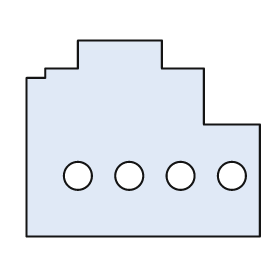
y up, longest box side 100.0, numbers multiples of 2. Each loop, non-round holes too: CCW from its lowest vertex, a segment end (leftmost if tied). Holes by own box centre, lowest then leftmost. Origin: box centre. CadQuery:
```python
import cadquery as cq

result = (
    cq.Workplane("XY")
    .moveTo(-50.0, -42.0)
    .lineTo(50.0, -42.0)
    .lineTo(50.0, 6.0)
    .lineTo(26.0, 6.0)
    .lineTo(26.0, 30.0)
    .lineTo(8.0, 30.0)
    .lineTo(8.0, 42.0)
    .lineTo(-28.0, 42.0)
    .lineTo(-28.0, 30.0)
    .lineTo(-42.0, 30.0)
    .lineTo(-42.0, 26.0)
    .lineTo(-50.0, 26.0)
    .close()
    .moveTo(-28.0, -16.0)
    .circle(6.0)
    .moveTo(-6.0, -16.0)
    .circle(6.0)
    .moveTo(16.0, -16.0)
    .circle(6.0)
    .moveTo(38.0, -16.0)
    .circle(6.0)
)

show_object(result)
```